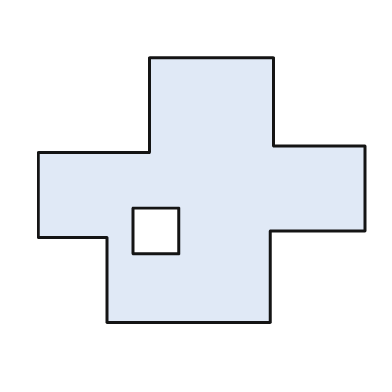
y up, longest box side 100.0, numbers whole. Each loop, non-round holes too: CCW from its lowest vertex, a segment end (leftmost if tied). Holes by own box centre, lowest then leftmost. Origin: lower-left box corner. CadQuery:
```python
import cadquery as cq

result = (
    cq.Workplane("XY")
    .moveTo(21.0, 0.0)
    .lineTo(71.0, 0.0)
    .lineTo(71.0, 28.0)
    .lineTo(100.0, 28.0)
    .lineTo(100.0, 54.0)
    .lineTo(72.0, 54.0)
    .lineTo(72.0, 81.0)
    .lineTo(34.0, 81.0)
    .lineTo(34.0, 52.0)
    .lineTo(0.0, 52.0)
    .lineTo(0.0, 26.0)
    .lineTo(21.0, 26.0)
    .close()
    .moveTo(29.0, 21.0)
    .lineTo(43.0, 21.0)
    .lineTo(43.0, 35.0)
    .lineTo(29.0, 35.0)
    .close()
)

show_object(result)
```